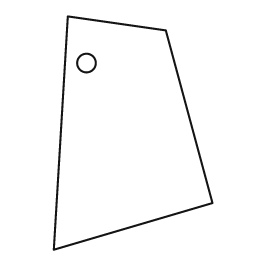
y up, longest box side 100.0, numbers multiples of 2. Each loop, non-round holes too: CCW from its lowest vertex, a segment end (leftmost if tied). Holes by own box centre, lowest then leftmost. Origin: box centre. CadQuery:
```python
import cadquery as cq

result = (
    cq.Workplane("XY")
    .moveTo(-34.0, -50.0)
    .lineTo(34.0, -30.0)
    .lineTo(14.0, 44.0)
    .lineTo(-28.0, 50.0)
    .close()
    .moveTo(-20.0, 30.0)
    .circle(4.0)
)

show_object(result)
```